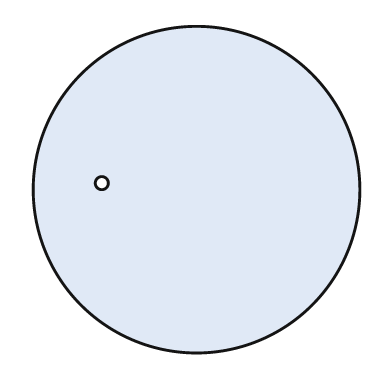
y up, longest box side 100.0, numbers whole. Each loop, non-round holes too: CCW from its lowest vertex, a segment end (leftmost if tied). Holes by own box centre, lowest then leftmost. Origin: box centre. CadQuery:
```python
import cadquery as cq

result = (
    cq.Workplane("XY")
    .moveTo(0.0, 0.0)
    .circle(50.0)
    .moveTo(-29.0, 2.0)
    .circle(2.0)
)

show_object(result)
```